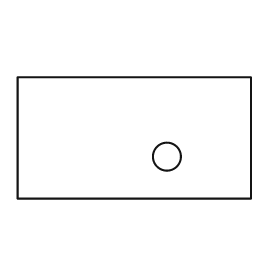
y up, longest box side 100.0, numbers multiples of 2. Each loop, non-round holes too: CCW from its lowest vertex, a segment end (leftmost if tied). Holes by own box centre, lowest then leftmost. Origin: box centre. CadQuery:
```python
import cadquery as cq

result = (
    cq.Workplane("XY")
    .moveTo(-50.0, -26.0)
    .lineTo(50.0, -26.0)
    .lineTo(50.0, 26.0)
    .lineTo(-50.0, 26.0)
    .close()
    .moveTo(14.0, -8.0)
    .circle(6.0)
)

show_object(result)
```